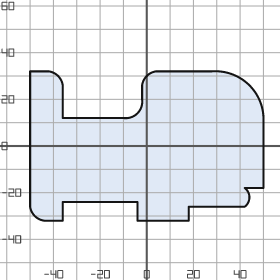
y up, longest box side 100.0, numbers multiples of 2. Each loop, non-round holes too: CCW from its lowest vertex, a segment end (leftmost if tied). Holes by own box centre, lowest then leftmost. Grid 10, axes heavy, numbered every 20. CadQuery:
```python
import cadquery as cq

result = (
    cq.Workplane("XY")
    .moveTo(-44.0, -32.0)
    .lineTo(-36.0, -32.0)
    .lineTo(-36.0, -24.0)
    .lineTo(-4.0, -24.0)
    .lineTo(-4.0, -32.0)
    .lineTo(18.0, -32.0)
    .lineTo(18.0, -26.0)
    .lineTo(42.0, -26.0)
    .threePointArc((44.0, -22.0), (42.0, -18.0))
    .lineTo(50.0, -18.0)
    .lineTo(50.0, 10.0)
    .threePointArc((44.0, 26.0), (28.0, 32.0))
    .lineTo(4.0, 32.0)
    .threePointArc((0.0, 30.0), (-2.0, 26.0))
    .lineTo(-2.0, 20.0)
    .threePointArc((-4.0, 14.0), (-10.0, 12.0))
    .lineTo(-36.0, 12.0)
    .lineTo(-36.0, 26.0)
    .threePointArc((-38.0, 30.0), (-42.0, 32.0))
    .lineTo(-50.0, 32.0)
    .lineTo(-50.0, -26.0)
    .threePointArc((-48.0, -30.0), (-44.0, -32.0))
    .close()
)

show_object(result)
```